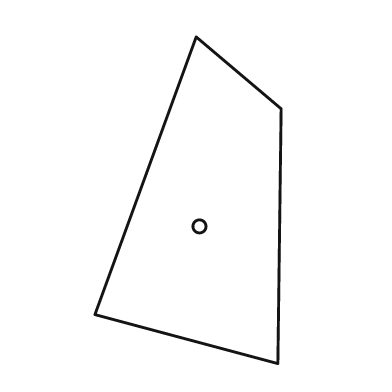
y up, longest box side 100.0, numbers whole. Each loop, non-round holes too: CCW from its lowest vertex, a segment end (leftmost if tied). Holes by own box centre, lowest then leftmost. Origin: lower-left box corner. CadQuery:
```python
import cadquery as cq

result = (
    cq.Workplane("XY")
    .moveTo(56.0, 0.0)
    .lineTo(57.0, 78.0)
    .lineTo(31.0, 100.0)
    .lineTo(0.0, 15.0)
    .close()
    .moveTo(32.0, 42.0)
    .circle(2.0)
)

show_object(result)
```